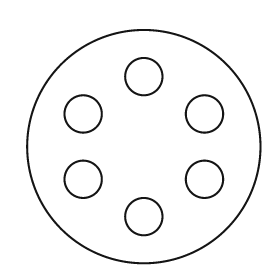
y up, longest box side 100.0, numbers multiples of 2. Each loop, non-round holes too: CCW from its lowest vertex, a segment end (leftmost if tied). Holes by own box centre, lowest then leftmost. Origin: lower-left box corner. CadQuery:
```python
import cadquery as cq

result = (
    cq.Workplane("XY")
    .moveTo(50.0, 50.0)
    .circle(50.0)
    .moveTo(50.0, 20.0)
    .circle(8.0)
    .moveTo(24.0, 36.0)
    .circle(8.0)
    .moveTo(76.0, 36.0)
    .circle(8.0)
    .moveTo(24.0, 64.0)
    .circle(8.0)
    .moveTo(76.0, 64.0)
    .circle(8.0)
    .moveTo(50.0, 80.0)
    .circle(8.0)
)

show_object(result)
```